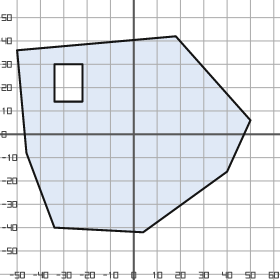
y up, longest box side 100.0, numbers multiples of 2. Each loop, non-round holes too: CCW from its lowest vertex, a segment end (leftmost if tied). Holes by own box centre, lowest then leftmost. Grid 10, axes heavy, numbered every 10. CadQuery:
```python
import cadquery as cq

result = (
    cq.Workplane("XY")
    .moveTo(4.0, -42.0)
    .lineTo(40.0, -16.0)
    .lineTo(50.0, 6.0)
    .lineTo(18.0, 42.0)
    .lineTo(-50.0, 36.0)
    .lineTo(-46.0, -8.0)
    .lineTo(-34.0, -40.0)
    .close()
    .moveTo(-34.0, 14.0)
    .lineTo(-22.0, 14.0)
    .lineTo(-22.0, 30.0)
    .lineTo(-34.0, 30.0)
    .close()
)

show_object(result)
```